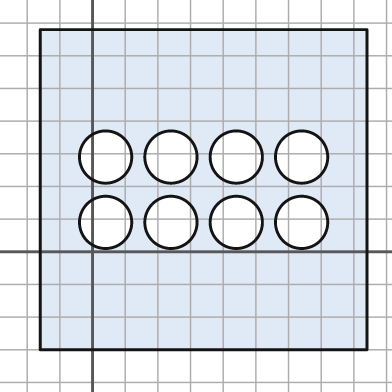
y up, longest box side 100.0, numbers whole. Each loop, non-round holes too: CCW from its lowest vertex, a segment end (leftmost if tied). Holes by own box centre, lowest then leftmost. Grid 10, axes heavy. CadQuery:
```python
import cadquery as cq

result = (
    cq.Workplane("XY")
    .moveTo(-16.0, -30.0)
    .lineTo(84.0, -30.0)
    .lineTo(84.0, 68.0)
    .lineTo(-16.0, 68.0)
    .close()
    .moveTo(4.0, 9.0)
    .circle(8.0)
    .moveTo(24.0, 9.0)
    .circle(8.0)
    .moveTo(44.0, 9.0)
    .circle(8.0)
    .moveTo(64.0, 9.0)
    .circle(8.0)
    .moveTo(4.0, 29.0)
    .circle(8.0)
    .moveTo(24.0, 29.0)
    .circle(8.0)
    .moveTo(44.0, 29.0)
    .circle(8.0)
    .moveTo(64.0, 29.0)
    .circle(8.0)
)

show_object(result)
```